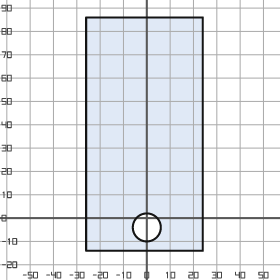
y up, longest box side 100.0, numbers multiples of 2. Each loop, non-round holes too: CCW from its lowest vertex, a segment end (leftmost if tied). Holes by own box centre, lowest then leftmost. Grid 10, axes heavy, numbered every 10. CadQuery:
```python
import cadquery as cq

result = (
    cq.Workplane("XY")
    .moveTo(-26.0, -14.0)
    .lineTo(24.0, -14.0)
    .lineTo(24.0, 86.0)
    .lineTo(-26.0, 86.0)
    .close()
    .moveTo(0.0, -4.0)
    .circle(6.0)
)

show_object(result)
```